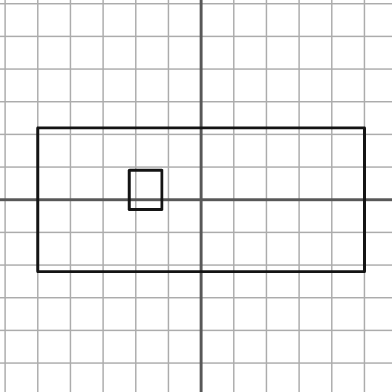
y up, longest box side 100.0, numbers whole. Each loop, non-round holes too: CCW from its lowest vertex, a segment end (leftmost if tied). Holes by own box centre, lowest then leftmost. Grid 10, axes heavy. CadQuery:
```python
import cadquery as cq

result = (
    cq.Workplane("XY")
    .moveTo(-50.0, -22.0)
    .lineTo(50.0, -22.0)
    .lineTo(50.0, 22.0)
    .lineTo(-50.0, 22.0)
    .close()
    .moveTo(-22.0, -3.0)
    .lineTo(-12.0, -3.0)
    .lineTo(-12.0, 9.0)
    .lineTo(-22.0, 9.0)
    .close()
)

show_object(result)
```